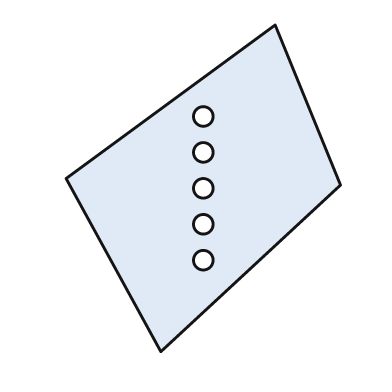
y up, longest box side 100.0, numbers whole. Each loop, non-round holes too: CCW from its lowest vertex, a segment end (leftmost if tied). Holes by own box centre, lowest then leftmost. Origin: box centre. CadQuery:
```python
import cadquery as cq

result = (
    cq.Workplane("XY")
    .moveTo(-13.0, -50.0)
    .lineTo(42.0, 1.0)
    .lineTo(22.0, 50.0)
    .lineTo(-42.0, 3.0)
    .close()
    .moveTo(0.0, -22.0)
    .circle(3.0)
    .moveTo(0.0, -11.0)
    .circle(3.0)
    .moveTo(0.0, 0.0)
    .circle(3.0)
    .moveTo(0.0, 11.0)
    .circle(3.0)
    .moveTo(0.0, 22.0)
    .circle(3.0)
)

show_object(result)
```